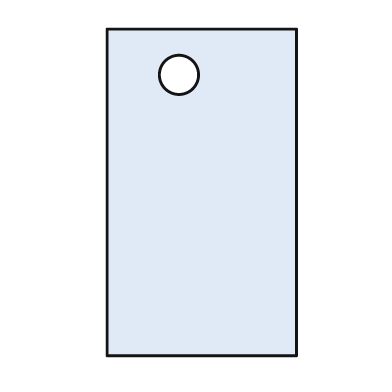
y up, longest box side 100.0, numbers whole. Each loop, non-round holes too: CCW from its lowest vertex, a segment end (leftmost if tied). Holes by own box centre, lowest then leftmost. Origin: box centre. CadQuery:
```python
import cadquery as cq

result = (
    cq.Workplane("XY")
    .moveTo(-29.0, -50.0)
    .lineTo(29.0, -50.0)
    .lineTo(29.0, 50.0)
    .lineTo(-29.0, 50.0)
    .close()
    .moveTo(-7.0, 36.0)
    .circle(6.0)
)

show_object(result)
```